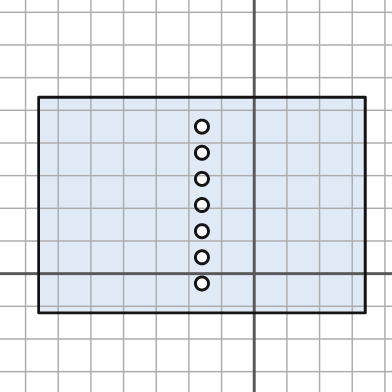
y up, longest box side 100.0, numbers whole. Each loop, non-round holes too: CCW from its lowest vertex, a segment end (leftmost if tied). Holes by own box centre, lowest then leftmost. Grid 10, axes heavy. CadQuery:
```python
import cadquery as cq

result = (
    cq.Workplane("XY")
    .moveTo(-66.0, -12.0)
    .lineTo(34.0, -12.0)
    .lineTo(34.0, 54.0)
    .lineTo(-66.0, 54.0)
    .close()
    .moveTo(-16.0, -3.0)
    .circle(2.0)
    .moveTo(-16.0, 5.0)
    .circle(2.0)
    .moveTo(-16.0, 13.0)
    .circle(2.0)
    .moveTo(-16.0, 21.0)
    .circle(2.0)
    .moveTo(-16.0, 29.0)
    .circle(2.0)
    .moveTo(-16.0, 37.0)
    .circle(2.0)
    .moveTo(-16.0, 45.0)
    .circle(2.0)
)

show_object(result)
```